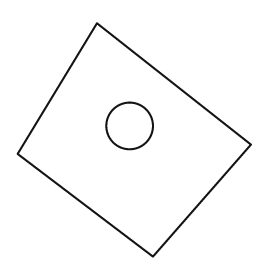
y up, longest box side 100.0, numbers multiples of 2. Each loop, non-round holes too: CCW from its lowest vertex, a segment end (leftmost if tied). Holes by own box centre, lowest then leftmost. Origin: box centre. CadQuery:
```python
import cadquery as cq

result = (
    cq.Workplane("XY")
    .moveTo(8.0, -50.0)
    .lineTo(50.0, -2.0)
    .lineTo(-16.0, 50.0)
    .lineTo(-50.0, -6.0)
    .close()
    .moveTo(-2.0, 6.0)
    .circle(10.0)
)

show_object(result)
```